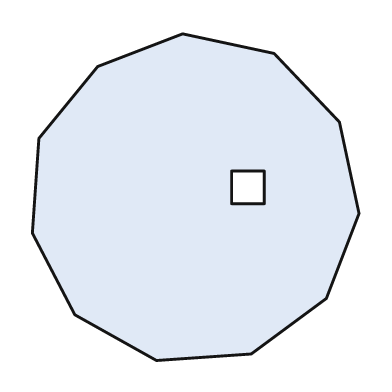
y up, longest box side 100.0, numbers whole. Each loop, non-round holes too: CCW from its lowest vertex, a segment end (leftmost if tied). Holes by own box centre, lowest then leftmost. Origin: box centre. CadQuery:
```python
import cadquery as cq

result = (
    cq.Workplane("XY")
    .moveTo(-12.0, -50.0)
    .lineTo(17.0, -48.0)
    .lineTo(40.0, -31.0)
    .lineTo(50.0, -5.0)
    .lineTo(44.0, 23.0)
    .lineTo(24.0, 44.0)
    .lineTo(-4.0, 50.0)
    .lineTo(-30.0, 40.0)
    .lineTo(-48.0, 18.0)
    .lineTo(-50.0, -11.0)
    .lineTo(-37.0, -36.0)
    .close()
    .moveTo(11.0, -2.0)
    .lineTo(21.0, -2.0)
    .lineTo(21.0, 8.0)
    .lineTo(11.0, 8.0)
    .close()
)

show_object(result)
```